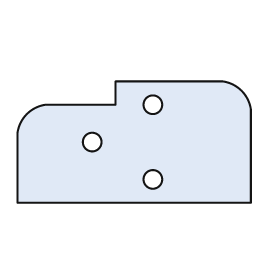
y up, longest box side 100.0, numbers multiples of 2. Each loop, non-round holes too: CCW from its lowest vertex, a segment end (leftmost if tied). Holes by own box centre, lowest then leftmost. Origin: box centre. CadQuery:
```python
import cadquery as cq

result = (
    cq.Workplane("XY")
    .moveTo(-50.0, -26.0)
    .lineTo(50.0, -26.0)
    .lineTo(50.0, 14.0)
    .threePointArc((46.0, 22.0), (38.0, 26.0))
    .lineTo(-8.0, 26.0)
    .lineTo(-8.0, 16.0)
    .lineTo(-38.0, 16.0)
    .threePointArc((-46.0, 12.0), (-50.0, 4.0))
    .close()
    .moveTo(8.0, -16.0)
    .circle(4.0)
    .moveTo(-18.0, 0.0)
    .circle(4.0)
    .moveTo(8.0, 16.0)
    .circle(4.0)
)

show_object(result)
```